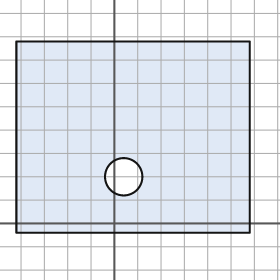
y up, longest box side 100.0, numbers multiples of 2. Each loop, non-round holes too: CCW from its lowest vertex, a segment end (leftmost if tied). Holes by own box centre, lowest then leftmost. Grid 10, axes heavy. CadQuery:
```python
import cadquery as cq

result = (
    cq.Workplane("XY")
    .moveTo(-42.0, -4.0)
    .lineTo(58.0, -4.0)
    .lineTo(58.0, 78.0)
    .lineTo(-42.0, 78.0)
    .close()
    .moveTo(4.0, 20.0)
    .circle(8.0)
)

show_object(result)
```